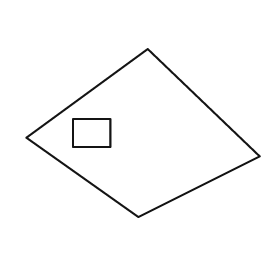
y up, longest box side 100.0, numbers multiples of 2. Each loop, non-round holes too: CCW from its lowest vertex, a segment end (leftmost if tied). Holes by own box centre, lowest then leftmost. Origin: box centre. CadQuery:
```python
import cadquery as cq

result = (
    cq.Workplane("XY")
    .moveTo(-2.0, -36.0)
    .lineTo(50.0, -10.0)
    .lineTo(2.0, 36.0)
    .lineTo(-50.0, -2.0)
    .close()
    .moveTo(-30.0, -6.0)
    .lineTo(-14.0, -6.0)
    .lineTo(-14.0, 6.0)
    .lineTo(-30.0, 6.0)
    .close()
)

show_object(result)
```